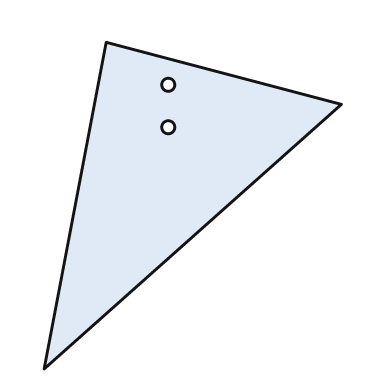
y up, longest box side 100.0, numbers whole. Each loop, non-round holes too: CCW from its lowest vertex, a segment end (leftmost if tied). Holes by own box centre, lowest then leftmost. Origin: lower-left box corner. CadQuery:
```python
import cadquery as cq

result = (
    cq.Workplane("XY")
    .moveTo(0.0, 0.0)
    .lineTo(91.0, 81.0)
    .lineTo(19.0, 100.0)
    .close()
    .moveTo(38.0, 74.0)
    .circle(2.0)
    .moveTo(38.0, 87.0)
    .circle(2.0)
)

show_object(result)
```